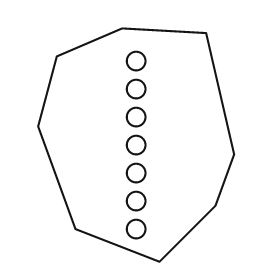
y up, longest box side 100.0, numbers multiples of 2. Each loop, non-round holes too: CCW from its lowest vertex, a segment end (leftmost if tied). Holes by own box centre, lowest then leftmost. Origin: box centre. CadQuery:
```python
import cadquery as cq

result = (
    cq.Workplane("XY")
    .moveTo(10.0, -50.0)
    .lineTo(34.0, -26.0)
    .lineTo(42.0, -4.0)
    .lineTo(30.0, 48.0)
    .lineTo(-6.0, 50.0)
    .lineTo(-34.0, 38.0)
    .lineTo(-42.0, 8.0)
    .lineTo(-26.0, -36.0)
    .close()
    .moveTo(0.0, -36.0)
    .circle(4.0)
    .moveTo(0.0, -24.0)
    .circle(4.0)
    .moveTo(0.0, -12.0)
    .circle(4.0)
    .moveTo(0.0, 0.0)
    .circle(4.0)
    .moveTo(0.0, 12.0)
    .circle(4.0)
    .moveTo(0.0, 24.0)
    .circle(4.0)
    .moveTo(0.0, 36.0)
    .circle(4.0)
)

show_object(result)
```